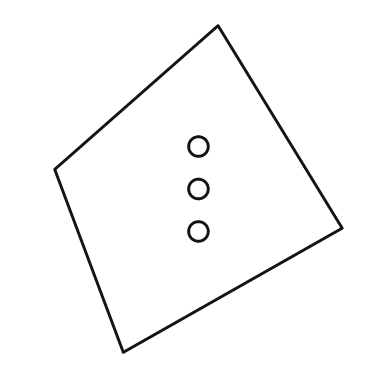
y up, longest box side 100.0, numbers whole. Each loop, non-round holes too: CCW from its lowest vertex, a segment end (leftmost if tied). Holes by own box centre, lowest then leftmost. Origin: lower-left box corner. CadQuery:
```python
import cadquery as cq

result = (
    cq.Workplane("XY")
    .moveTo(21.0, 0.0)
    .lineTo(88.0, 38.0)
    .lineTo(50.0, 100.0)
    .lineTo(0.0, 56.0)
    .close()
    .moveTo(44.0, 37.0)
    .circle(3.0)
    .moveTo(44.0, 50.0)
    .circle(3.0)
    .moveTo(44.0, 63.0)
    .circle(3.0)
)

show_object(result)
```